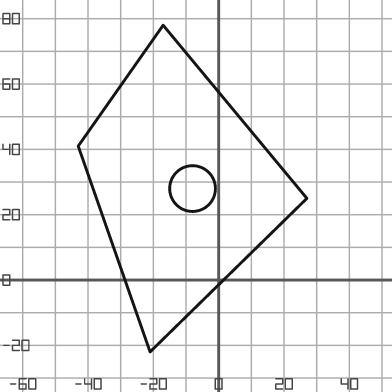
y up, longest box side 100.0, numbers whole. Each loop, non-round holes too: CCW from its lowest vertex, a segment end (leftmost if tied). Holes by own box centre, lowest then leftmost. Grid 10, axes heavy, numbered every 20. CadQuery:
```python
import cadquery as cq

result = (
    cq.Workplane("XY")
    .moveTo(-21.0, -22.0)
    .lineTo(27.0, 25.0)
    .lineTo(-17.0, 78.0)
    .lineTo(-43.0, 41.0)
    .close()
    .moveTo(-8.0, 28.0)
    .circle(7.0)
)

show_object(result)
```